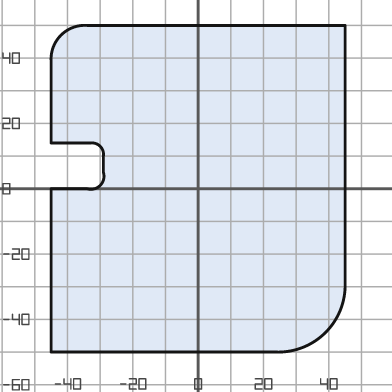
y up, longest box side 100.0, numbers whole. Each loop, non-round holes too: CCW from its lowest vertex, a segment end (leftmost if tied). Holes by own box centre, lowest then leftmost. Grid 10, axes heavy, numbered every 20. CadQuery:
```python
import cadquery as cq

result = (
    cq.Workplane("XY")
    .moveTo(-45.0, -50.0)
    .lineTo(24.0, -50.0)
    .threePointArc((39.0, -44.0), (45.0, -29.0))
    .lineTo(45.0, 50.0)
    .lineTo(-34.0, 50.0)
    .threePointArc((-42.0, 47.0), (-45.0, 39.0))
    .lineTo(-45.0, 14.0)
    .lineTo(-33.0, 14.0)
    .threePointArc((-30.0, 13.0), (-29.0, 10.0))
    .lineTo(-29.0, 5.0)
    .threePointArc((-30.0, 1.0), (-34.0, 0.0))
    .lineTo(-45.0, 0.0)
    .close()
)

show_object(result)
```